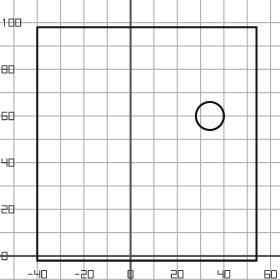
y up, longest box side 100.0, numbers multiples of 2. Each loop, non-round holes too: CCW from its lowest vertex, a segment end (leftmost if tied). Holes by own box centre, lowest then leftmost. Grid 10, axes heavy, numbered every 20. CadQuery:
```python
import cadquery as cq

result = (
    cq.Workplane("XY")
    .moveTo(-40.0, -2.0)
    .lineTo(54.0, -2.0)
    .lineTo(54.0, 98.0)
    .lineTo(-40.0, 98.0)
    .close()
    .moveTo(34.0, 60.0)
    .circle(6.0)
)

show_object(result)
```